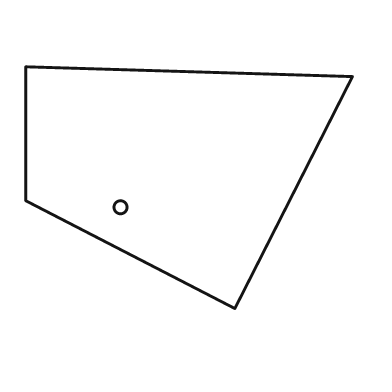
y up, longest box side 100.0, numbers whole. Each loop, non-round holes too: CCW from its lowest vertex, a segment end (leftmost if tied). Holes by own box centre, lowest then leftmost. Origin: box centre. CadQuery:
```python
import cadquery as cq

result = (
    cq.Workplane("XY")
    .moveTo(14.0, -37.0)
    .lineTo(50.0, 34.0)
    .lineTo(-50.0, 37.0)
    .lineTo(-50.0, -4.0)
    .close()
    .moveTo(-21.0, -6.0)
    .circle(2.0)
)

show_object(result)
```